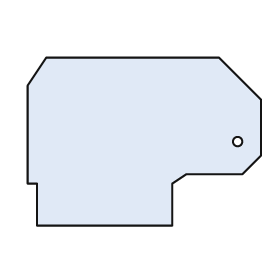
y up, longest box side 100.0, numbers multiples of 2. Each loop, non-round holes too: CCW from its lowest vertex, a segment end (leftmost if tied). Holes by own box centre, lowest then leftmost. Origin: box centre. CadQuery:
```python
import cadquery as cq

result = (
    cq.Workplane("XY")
    .moveTo(-46.0, -36.0)
    .lineTo(12.0, -36.0)
    .lineTo(12.0, -18.0)
    .lineTo(18.0, -14.0)
    .lineTo(42.0, -14.0)
    .lineTo(50.0, -6.0)
    .lineTo(50.0, 18.0)
    .lineTo(32.0, 36.0)
    .lineTo(-42.0, 36.0)
    .lineTo(-50.0, 24.0)
    .lineTo(-50.0, -18.0)
    .lineTo(-46.0, -18.0)
    .close()
    .moveTo(40.0, 0.0)
    .circle(2.0)
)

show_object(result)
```